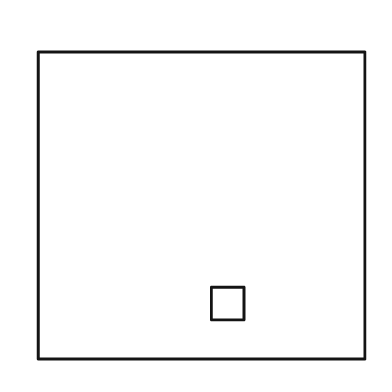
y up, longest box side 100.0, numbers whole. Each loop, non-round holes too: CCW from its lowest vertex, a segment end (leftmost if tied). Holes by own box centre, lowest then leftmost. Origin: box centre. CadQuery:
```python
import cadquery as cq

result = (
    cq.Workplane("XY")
    .moveTo(-50.0, -47.0)
    .lineTo(50.0, -47.0)
    .lineTo(50.0, 47.0)
    .lineTo(-50.0, 47.0)
    .close()
    .moveTo(3.0, -35.0)
    .lineTo(13.0, -35.0)
    .lineTo(13.0, -25.0)
    .lineTo(3.0, -25.0)
    .close()
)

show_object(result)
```